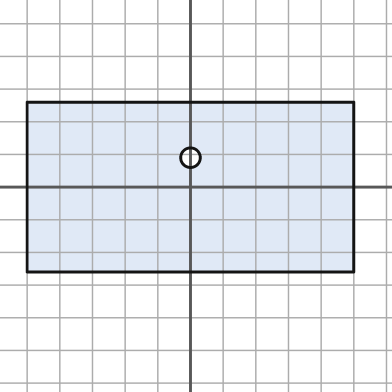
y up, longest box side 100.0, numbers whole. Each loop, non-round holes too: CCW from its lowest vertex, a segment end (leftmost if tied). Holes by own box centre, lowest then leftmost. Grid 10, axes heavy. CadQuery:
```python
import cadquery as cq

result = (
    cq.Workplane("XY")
    .moveTo(-50.0, -26.0)
    .lineTo(50.0, -26.0)
    .lineTo(50.0, 26.0)
    .lineTo(-50.0, 26.0)
    .close()
    .moveTo(0.0, 9.0)
    .circle(3.0)
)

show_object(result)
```